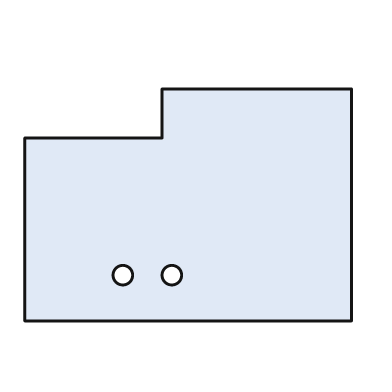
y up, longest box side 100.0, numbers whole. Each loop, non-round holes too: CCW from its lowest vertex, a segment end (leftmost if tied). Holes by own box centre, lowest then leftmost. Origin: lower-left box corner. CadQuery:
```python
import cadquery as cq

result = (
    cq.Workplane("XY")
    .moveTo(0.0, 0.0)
    .lineTo(100.0, 0.0)
    .lineTo(100.0, 71.0)
    .lineTo(42.0, 71.0)
    .lineTo(42.0, 56.0)
    .lineTo(0.0, 56.0)
    .close()
    .moveTo(30.0, 14.0)
    .circle(3.0)
    .moveTo(45.0, 14.0)
    .circle(3.0)
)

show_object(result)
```